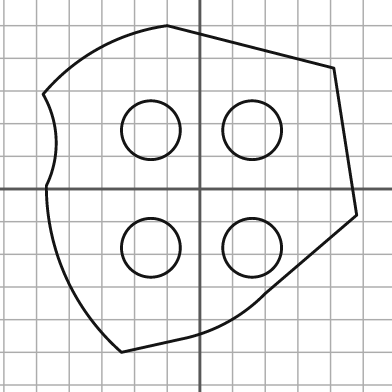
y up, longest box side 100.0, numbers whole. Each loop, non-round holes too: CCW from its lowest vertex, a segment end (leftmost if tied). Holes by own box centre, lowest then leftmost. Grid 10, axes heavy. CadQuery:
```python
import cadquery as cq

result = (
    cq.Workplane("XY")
    .moveTo(-24.0, -50.0)
    .lineTo(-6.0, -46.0)
    .threePointArc((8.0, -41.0), (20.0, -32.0))
    .lineTo(48.0, -8.0)
    .lineTo(41.0, 37.0)
    .lineTo(-10.0, 50.0)
    .threePointArc((-31.0, 43.0), (-48.0, 29.0))
    .threePointArc((-44.0, 15.0), (-47.0, 1.0))
    .threePointArc((-41.0, -27.0), (-24.0, -50.0))
    .close()
    .moveTo(-15.0, -18.0)
    .circle(9.0)
    .moveTo(16.0, -18.0)
    .circle(9.0)
    .moveTo(-15.0, 18.0)
    .circle(9.0)
    .moveTo(16.0, 18.0)
    .circle(9.0)
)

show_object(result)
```